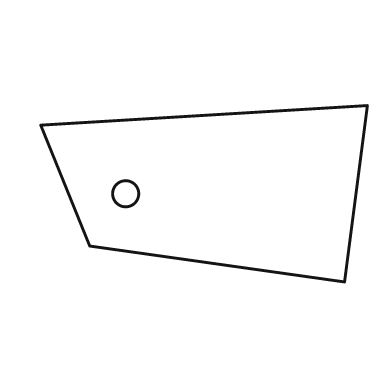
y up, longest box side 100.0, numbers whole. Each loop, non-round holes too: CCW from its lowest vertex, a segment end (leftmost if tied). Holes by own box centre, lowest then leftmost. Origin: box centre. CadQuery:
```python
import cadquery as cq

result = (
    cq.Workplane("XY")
    .moveTo(43.0, -27.0)
    .lineTo(50.0, 27.0)
    .lineTo(-50.0, 21.0)
    .lineTo(-35.0, -16.0)
    .close()
    .moveTo(-24.0, 0.0)
    .circle(4.0)
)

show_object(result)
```